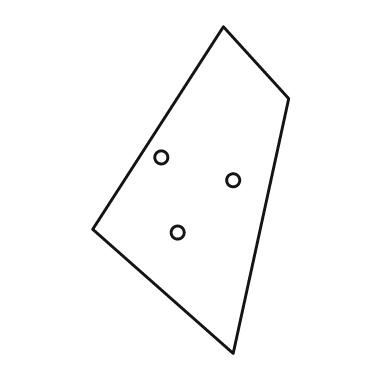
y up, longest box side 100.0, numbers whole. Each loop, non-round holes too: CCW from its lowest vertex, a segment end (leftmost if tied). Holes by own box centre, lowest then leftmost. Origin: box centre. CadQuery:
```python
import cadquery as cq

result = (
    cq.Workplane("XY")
    .moveTo(13.0, -50.0)
    .lineTo(30.0, 28.0)
    .lineTo(10.0, 50.0)
    .lineTo(-30.0, -12.0)
    .close()
    .moveTo(-4.0, -13.0)
    .circle(2.0)
    .moveTo(13.0, 3.0)
    .circle(2.0)
    .moveTo(-9.0, 10.0)
    .circle(2.0)
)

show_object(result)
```